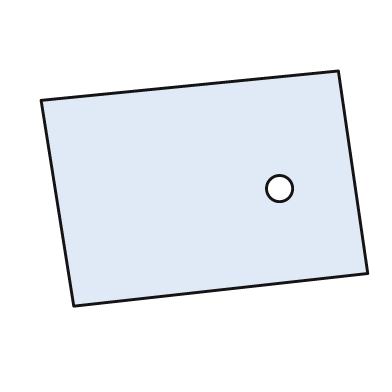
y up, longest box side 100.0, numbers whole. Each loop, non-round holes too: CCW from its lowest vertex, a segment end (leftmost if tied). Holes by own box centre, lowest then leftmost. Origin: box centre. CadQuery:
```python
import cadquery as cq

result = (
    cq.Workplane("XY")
    .moveTo(-40.0, -36.0)
    .lineTo(50.0, -26.0)
    .lineTo(41.0, 36.0)
    .lineTo(-50.0, 27.0)
    .close()
    .moveTo(23.0, 0.0)
    .circle(4.0)
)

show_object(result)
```